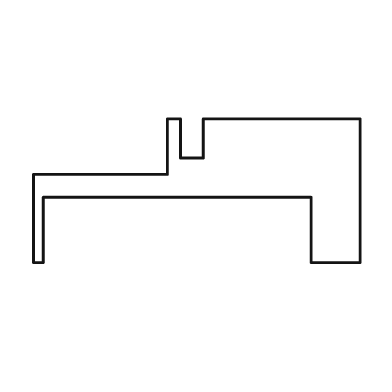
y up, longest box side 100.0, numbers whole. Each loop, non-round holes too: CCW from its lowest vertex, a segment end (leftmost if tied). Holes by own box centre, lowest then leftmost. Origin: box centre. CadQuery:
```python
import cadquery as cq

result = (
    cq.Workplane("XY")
    .moveTo(-50.0, -22.0)
    .lineTo(-47.0, -22.0)
    .lineTo(-47.0, -2.0)
    .lineTo(35.0, -2.0)
    .lineTo(35.0, -22.0)
    .lineTo(50.0, -22.0)
    .lineTo(50.0, 22.0)
    .lineTo(2.0, 22.0)
    .lineTo(2.0, 10.0)
    .lineTo(-5.0, 10.0)
    .lineTo(-5.0, 22.0)
    .lineTo(-9.0, 22.0)
    .lineTo(-9.0, 5.0)
    .lineTo(-50.0, 5.0)
    .close()
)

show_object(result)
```